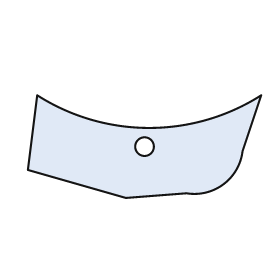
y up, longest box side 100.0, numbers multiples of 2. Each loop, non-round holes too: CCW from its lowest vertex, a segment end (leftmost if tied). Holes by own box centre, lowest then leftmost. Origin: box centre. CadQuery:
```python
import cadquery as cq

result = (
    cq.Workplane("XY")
    .moveTo(-8.0, -22.0)
    .lineTo(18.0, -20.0)
    .threePointArc((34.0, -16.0), (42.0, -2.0))
    .lineTo(50.0, 22.0)
    .threePointArc((2.0, 8.0), (-46.0, 22.0))
    .lineTo(-50.0, -10.0)
    .close()
    .moveTo(0.0, 0.0)
    .circle(4.0)
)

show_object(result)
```